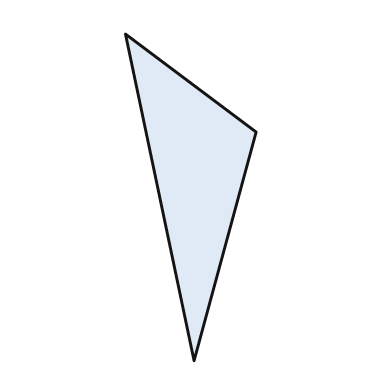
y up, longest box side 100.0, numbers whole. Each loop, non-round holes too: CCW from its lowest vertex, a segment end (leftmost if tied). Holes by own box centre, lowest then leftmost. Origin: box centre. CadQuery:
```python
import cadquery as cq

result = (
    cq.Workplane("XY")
    .moveTo(1.0, -50.0)
    .lineTo(20.0, 20.0)
    .lineTo(-20.0, 50.0)
    .close()
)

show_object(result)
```